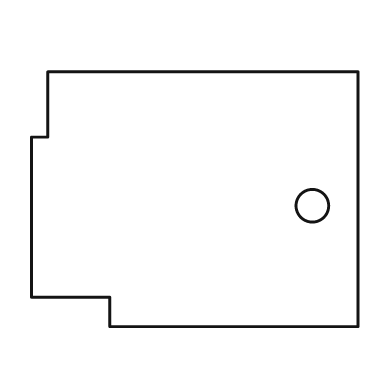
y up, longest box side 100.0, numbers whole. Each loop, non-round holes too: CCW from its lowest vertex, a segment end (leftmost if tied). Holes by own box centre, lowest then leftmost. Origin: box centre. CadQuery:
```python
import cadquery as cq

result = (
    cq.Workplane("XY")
    .moveTo(-26.0, -39.0)
    .lineTo(50.0, -39.0)
    .lineTo(50.0, 39.0)
    .lineTo(-45.0, 39.0)
    .lineTo(-45.0, 19.0)
    .lineTo(-50.0, 19.0)
    .lineTo(-50.0, -30.0)
    .lineTo(-26.0, -30.0)
    .close()
    .moveTo(36.0, -2.0)
    .circle(5.0)
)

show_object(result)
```